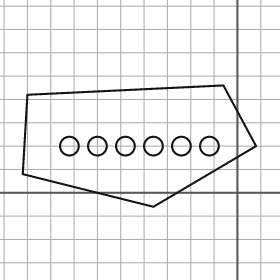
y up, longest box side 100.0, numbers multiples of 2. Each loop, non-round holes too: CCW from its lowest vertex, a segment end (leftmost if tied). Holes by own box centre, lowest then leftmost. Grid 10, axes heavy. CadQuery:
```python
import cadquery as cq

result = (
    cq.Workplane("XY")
    .moveTo(-36.0, -6.0)
    .lineTo(8.0, 20.0)
    .lineTo(-6.0, 46.0)
    .lineTo(-90.0, 42.0)
    .lineTo(-92.0, 8.0)
    .close()
    .moveTo(-72.0, 20.0)
    .circle(4.0)
    .moveTo(-60.0, 20.0)
    .circle(4.0)
    .moveTo(-48.0, 20.0)
    .circle(4.0)
    .moveTo(-36.0, 20.0)
    .circle(4.0)
    .moveTo(-24.0, 20.0)
    .circle(4.0)
    .moveTo(-12.0, 20.0)
    .circle(4.0)
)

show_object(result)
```